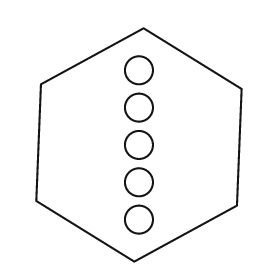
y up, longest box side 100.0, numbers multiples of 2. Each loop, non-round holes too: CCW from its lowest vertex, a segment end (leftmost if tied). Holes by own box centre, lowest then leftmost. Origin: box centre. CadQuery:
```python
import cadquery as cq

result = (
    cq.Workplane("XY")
    .moveTo(-2.0, -50.0)
    .lineTo(42.0, -26.0)
    .lineTo(44.0, 24.0)
    .lineTo(2.0, 50.0)
    .lineTo(-42.0, 26.0)
    .lineTo(-44.0, -24.0)
    .close()
    .moveTo(0.0, -32.0)
    .circle(6.0)
    .moveTo(0.0, -16.0)
    .circle(6.0)
    .moveTo(0.0, 0.0)
    .circle(6.0)
    .moveTo(0.0, 16.0)
    .circle(6.0)
    .moveTo(0.0, 32.0)
    .circle(6.0)
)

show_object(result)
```